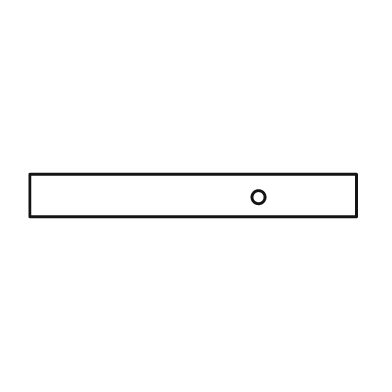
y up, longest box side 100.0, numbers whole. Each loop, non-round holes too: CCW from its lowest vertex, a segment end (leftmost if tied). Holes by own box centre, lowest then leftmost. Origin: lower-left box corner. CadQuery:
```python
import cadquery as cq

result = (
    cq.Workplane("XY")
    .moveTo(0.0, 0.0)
    .lineTo(100.0, 0.0)
    .lineTo(100.0, 13.0)
    .lineTo(0.0, 13.0)
    .close()
    .moveTo(70.0, 6.0)
    .circle(2.0)
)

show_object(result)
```